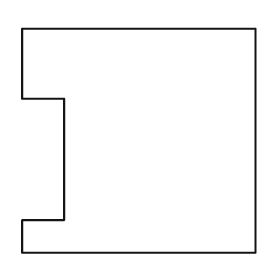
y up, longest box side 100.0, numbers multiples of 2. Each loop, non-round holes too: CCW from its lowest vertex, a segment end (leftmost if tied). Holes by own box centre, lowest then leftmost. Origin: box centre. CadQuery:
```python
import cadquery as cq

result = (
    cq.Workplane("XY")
    .moveTo(-50.0, -48.0)
    .lineTo(50.0, -48.0)
    .lineTo(50.0, 48.0)
    .lineTo(-50.0, 48.0)
    .lineTo(-50.0, 18.0)
    .lineTo(-32.0, 18.0)
    .lineTo(-32.0, -34.0)
    .lineTo(-50.0, -34.0)
    .close()
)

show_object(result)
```